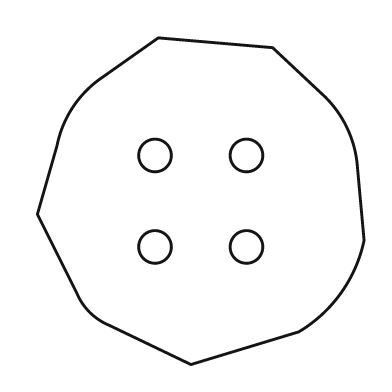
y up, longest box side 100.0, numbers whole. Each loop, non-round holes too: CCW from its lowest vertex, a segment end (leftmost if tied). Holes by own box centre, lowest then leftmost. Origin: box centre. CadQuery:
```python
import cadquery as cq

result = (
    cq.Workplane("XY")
    .moveTo(-3.0, -50.0)
    .lineTo(30.0, -40.0)
    .threePointArc((43.0, -28.0), (50.0, -12.0))
    .lineTo(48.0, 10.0)
    .threePointArc((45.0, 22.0), (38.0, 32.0))
    .lineTo(22.0, 47.0)
    .lineTo(-13.0, 50.0)
    .lineTo(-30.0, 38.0)
    .threePointArc((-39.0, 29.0), (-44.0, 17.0))
    .lineTo(-50.0, -4.0)
    .lineTo(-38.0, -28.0)
    .threePointArc((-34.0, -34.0), (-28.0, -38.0))
    .close()
    .moveTo(-14.0, -14.0)
    .circle(5.0)
    .moveTo(14.0, -14.0)
    .circle(5.0)
    .moveTo(-14.0, 14.0)
    .circle(5.0)
    .moveTo(14.0, 14.0)
    .circle(5.0)
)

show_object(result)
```